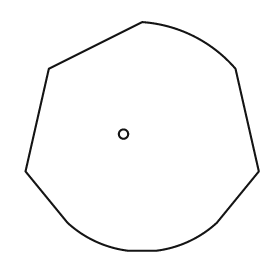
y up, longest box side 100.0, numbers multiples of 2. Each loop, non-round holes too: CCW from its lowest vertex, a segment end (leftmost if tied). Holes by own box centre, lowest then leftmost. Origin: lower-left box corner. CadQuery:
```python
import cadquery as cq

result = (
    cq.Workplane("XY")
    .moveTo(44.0, 0.0)
    .lineTo(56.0, 0.0)
    .threePointArc((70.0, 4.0), (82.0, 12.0))
    .lineTo(100.0, 34.0)
    .lineTo(90.0, 78.0)
    .threePointArc((72.0, 92.0), (50.0, 98.0))
    .lineTo(10.0, 78.0)
    .lineTo(0.0, 34.0)
    .lineTo(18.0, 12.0)
    .threePointArc((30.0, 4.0), (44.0, 0.0))
    .close()
    .moveTo(42.0, 50.0)
    .circle(2.0)
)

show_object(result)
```